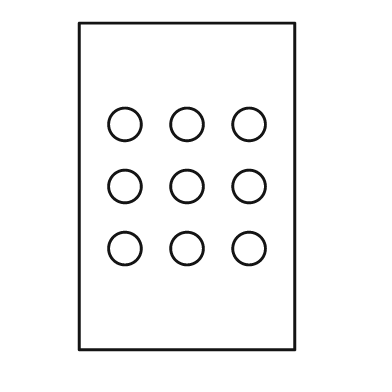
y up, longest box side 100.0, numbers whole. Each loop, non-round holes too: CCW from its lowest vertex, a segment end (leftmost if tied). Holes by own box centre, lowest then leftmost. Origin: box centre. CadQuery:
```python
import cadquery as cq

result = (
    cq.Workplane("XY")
    .moveTo(-33.0, -50.0)
    .lineTo(33.0, -50.0)
    .lineTo(33.0, 50.0)
    .lineTo(-33.0, 50.0)
    .close()
    .moveTo(-19.0, -19.0)
    .circle(5.0)
    .moveTo(0.0, -19.0)
    .circle(5.0)
    .moveTo(19.0, -19.0)
    .circle(5.0)
    .moveTo(-19.0, 0.0)
    .circle(5.0)
    .moveTo(0.0, 0.0)
    .circle(5.0)
    .moveTo(19.0, 0.0)
    .circle(5.0)
    .moveTo(-19.0, 19.0)
    .circle(5.0)
    .moveTo(0.0, 19.0)
    .circle(5.0)
    .moveTo(19.0, 19.0)
    .circle(5.0)
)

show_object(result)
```